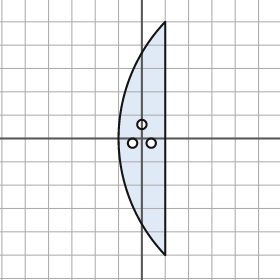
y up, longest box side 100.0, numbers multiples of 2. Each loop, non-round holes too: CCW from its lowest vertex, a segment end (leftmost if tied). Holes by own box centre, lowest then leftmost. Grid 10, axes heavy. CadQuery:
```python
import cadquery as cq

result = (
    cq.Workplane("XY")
    .moveTo(10.0, -50.0)
    .lineTo(10.0, 50.0)
    .threePointArc((-10.0, 0.0), (10.0, -50.0))
    .close()
    .moveTo(-4.0, -2.0)
    .circle(2.0)
    .moveTo(4.0, -2.0)
    .circle(2.0)
    .moveTo(0.0, 6.0)
    .circle(2.0)
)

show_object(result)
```